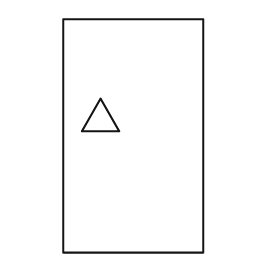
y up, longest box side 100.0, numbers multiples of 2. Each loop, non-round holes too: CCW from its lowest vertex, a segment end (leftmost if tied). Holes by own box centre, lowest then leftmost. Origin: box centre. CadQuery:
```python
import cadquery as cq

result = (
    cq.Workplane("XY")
    .moveTo(-30.0, -50.0)
    .lineTo(30.0, -50.0)
    .lineTo(30.0, 50.0)
    .lineTo(-30.0, 50.0)
    .close()
    .moveTo(-22.0, 2.0)
    .lineTo(-6.0, 2.0)
    .lineTo(-14.0, 16.0)
    .close()
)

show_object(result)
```